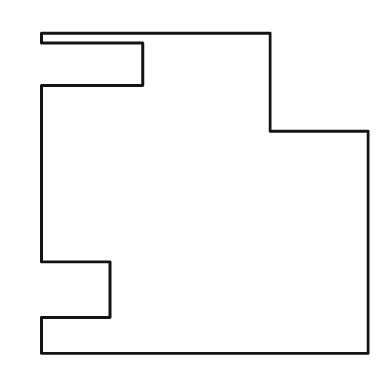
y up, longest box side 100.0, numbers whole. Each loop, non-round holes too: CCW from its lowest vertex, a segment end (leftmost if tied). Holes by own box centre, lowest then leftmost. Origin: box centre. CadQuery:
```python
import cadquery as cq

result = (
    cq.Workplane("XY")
    .moveTo(-50.0, -49.0)
    .lineTo(50.0, -49.0)
    .lineTo(50.0, 19.0)
    .lineTo(20.0, 19.0)
    .lineTo(20.0, 49.0)
    .lineTo(-50.0, 49.0)
    .lineTo(-50.0, 46.0)
    .lineTo(-19.0, 46.0)
    .lineTo(-19.0, 33.0)
    .lineTo(-50.0, 33.0)
    .lineTo(-50.0, -21.0)
    .lineTo(-29.0, -21.0)
    .lineTo(-29.0, -38.0)
    .lineTo(-50.0, -38.0)
    .close()
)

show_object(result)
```